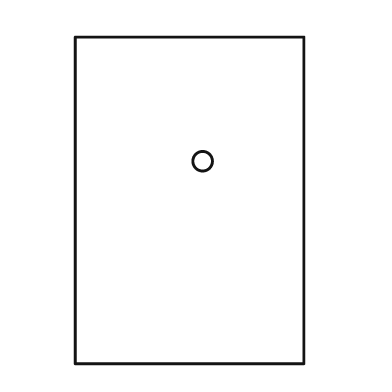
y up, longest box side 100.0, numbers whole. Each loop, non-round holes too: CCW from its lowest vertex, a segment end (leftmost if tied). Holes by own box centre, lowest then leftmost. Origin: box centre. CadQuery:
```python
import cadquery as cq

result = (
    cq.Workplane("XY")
    .moveTo(-35.0, -50.0)
    .lineTo(35.0, -50.0)
    .lineTo(35.0, 50.0)
    .lineTo(-35.0, 50.0)
    .close()
    .moveTo(4.0, 12.0)
    .circle(3.0)
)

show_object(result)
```